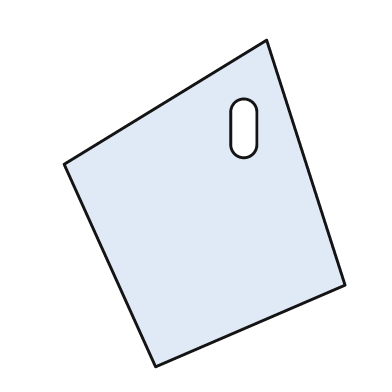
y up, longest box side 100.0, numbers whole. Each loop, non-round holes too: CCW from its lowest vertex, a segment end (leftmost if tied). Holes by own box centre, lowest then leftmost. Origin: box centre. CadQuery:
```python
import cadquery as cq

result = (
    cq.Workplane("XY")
    .moveTo(-15.0, -50.0)
    .lineTo(43.0, -25.0)
    .lineTo(19.0, 50.0)
    .lineTo(-43.0, 12.0)
    .close()
    .moveTo(8.0, 18.0)
    .threePointArc((12.0, 14.0), (16.0, 18.0))
    .lineTo(16.0, 28.0)
    .threePointArc((12.0, 32.0), (8.0, 28.0))
    .close()
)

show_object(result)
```